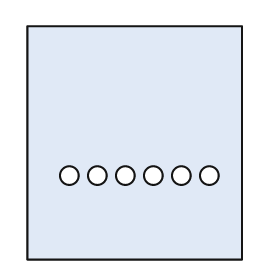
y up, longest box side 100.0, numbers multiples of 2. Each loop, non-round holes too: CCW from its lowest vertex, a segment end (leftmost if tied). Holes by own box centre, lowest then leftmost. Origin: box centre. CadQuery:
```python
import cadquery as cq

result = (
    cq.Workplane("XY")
    .moveTo(-46.0, -50.0)
    .lineTo(46.0, -50.0)
    .lineTo(46.0, 50.0)
    .lineTo(-46.0, 50.0)
    .close()
    .moveTo(-28.0, -14.0)
    .circle(4.0)
    .moveTo(-16.0, -14.0)
    .circle(4.0)
    .moveTo(-4.0, -14.0)
    .circle(4.0)
    .moveTo(8.0, -14.0)
    .circle(4.0)
    .moveTo(20.0, -14.0)
    .circle(4.0)
    .moveTo(32.0, -14.0)
    .circle(4.0)
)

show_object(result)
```